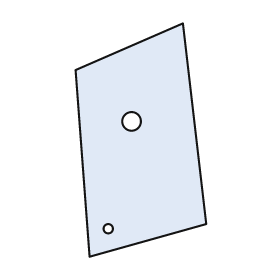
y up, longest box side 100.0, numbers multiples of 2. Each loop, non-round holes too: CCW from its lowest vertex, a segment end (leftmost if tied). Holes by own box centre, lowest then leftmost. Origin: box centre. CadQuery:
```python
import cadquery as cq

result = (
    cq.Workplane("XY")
    .moveTo(-22.0, -50.0)
    .lineTo(28.0, -36.0)
    .lineTo(18.0, 50.0)
    .lineTo(-28.0, 30.0)
    .close()
    .moveTo(-14.0, -38.0)
    .circle(2.0)
    .moveTo(-4.0, 8.0)
    .circle(4.0)
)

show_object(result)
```